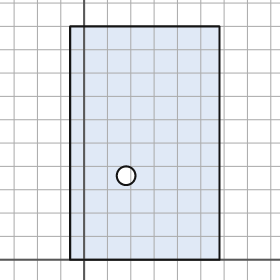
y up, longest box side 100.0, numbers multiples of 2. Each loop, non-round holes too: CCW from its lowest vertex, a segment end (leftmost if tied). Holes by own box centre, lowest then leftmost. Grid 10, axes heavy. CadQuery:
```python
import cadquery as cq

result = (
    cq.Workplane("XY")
    .moveTo(-6.0, 0.0)
    .lineTo(58.0, 0.0)
    .lineTo(58.0, 100.0)
    .lineTo(-6.0, 100.0)
    .close()
    .moveTo(18.0, 36.0)
    .circle(4.0)
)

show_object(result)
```